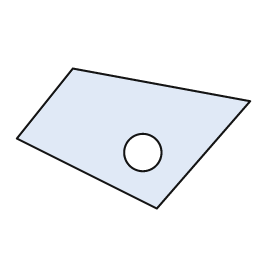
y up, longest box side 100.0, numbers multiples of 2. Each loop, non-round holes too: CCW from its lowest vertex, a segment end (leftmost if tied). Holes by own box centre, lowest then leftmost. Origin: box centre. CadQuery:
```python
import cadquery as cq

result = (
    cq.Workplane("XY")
    .moveTo(10.0, -30.0)
    .lineTo(50.0, 16.0)
    .lineTo(-26.0, 30.0)
    .lineTo(-50.0, 0.0)
    .close()
    .moveTo(4.0, -6.0)
    .circle(8.0)
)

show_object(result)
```